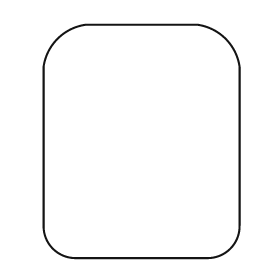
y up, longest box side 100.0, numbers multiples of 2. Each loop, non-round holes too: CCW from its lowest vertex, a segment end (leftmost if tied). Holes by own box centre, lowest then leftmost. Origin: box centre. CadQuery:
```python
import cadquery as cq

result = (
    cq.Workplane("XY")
    .moveTo(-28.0, -50.0)
    .lineTo(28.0, -50.0)
    .threePointArc((38.0, -46.0), (42.0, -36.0))
    .lineTo(42.0, 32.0)
    .threePointArc((36.0, 44.0), (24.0, 50.0))
    .lineTo(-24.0, 50.0)
    .threePointArc((-36.0, 44.0), (-42.0, 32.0))
    .lineTo(-42.0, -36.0)
    .threePointArc((-38.0, -46.0), (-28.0, -50.0))
    .close()
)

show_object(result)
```